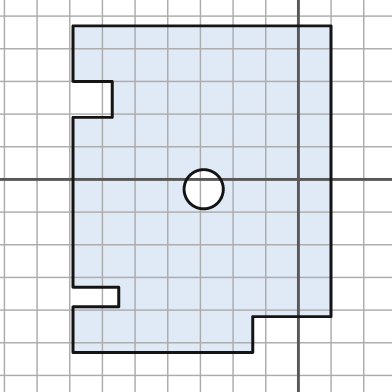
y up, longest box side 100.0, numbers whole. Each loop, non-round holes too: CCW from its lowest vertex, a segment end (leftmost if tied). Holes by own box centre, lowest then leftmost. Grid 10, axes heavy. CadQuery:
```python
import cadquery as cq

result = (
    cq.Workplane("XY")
    .moveTo(-69.0, -53.0)
    .lineTo(-14.0, -53.0)
    .lineTo(-14.0, -42.0)
    .lineTo(10.0, -42.0)
    .lineTo(10.0, 47.0)
    .lineTo(-69.0, 47.0)
    .lineTo(-69.0, 30.0)
    .lineTo(-57.0, 30.0)
    .lineTo(-57.0, 19.0)
    .lineTo(-69.0, 19.0)
    .lineTo(-69.0, -33.0)
    .lineTo(-55.0, -33.0)
    .lineTo(-55.0, -39.0)
    .lineTo(-69.0, -39.0)
    .close()
    .moveTo(-29.0, -3.0)
    .circle(6.0)
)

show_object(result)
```